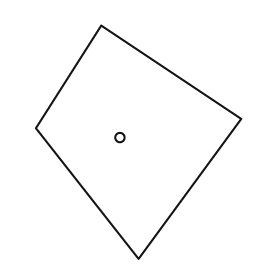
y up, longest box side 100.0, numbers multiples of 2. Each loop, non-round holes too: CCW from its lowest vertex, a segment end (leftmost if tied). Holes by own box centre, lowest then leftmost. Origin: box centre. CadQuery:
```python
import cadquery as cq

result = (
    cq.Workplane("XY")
    .moveTo(0.0, -50.0)
    .lineTo(44.0, 10.0)
    .lineTo(-16.0, 50.0)
    .lineTo(-44.0, 6.0)
    .close()
    .moveTo(-8.0, 2.0)
    .circle(2.0)
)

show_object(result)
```